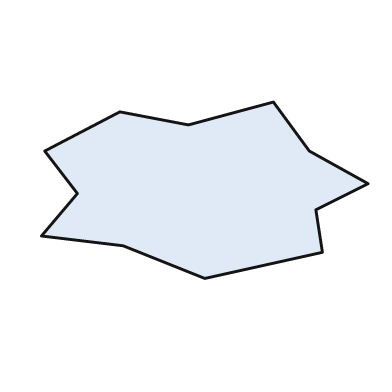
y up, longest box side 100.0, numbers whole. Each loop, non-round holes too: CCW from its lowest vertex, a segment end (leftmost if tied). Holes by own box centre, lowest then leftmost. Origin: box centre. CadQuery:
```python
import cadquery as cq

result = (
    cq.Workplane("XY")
    .moveTo(0.0, -27.0)
    .lineTo(36.0, -19.0)
    .lineTo(34.0, -6.0)
    .lineTo(50.0, 2.0)
    .lineTo(32.0, 12.0)
    .lineTo(21.0, 27.0)
    .lineTo(-5.0, 20.0)
    .lineTo(-26.0, 24.0)
    .lineTo(-49.0, 12.0)
    .lineTo(-39.0, -1.0)
    .lineTo(-50.0, -14.0)
    .lineTo(-25.0, -17.0)
    .close()
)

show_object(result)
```